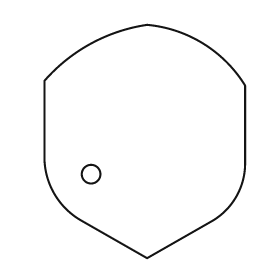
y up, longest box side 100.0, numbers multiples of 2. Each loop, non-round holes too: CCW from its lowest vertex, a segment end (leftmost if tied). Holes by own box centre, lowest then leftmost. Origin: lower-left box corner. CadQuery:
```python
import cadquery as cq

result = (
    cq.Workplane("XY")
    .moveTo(44.0, 0.0)
    .lineTo(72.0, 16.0)
    .threePointArc((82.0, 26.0), (86.0, 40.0))
    .lineTo(86.0, 74.0)
    .threePointArc((68.0, 92.0), (44.0, 100.0))
    .threePointArc((20.0, 92.0), (0.0, 76.0))
    .lineTo(0.0, 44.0)
    .threePointArc((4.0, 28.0), (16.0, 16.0))
    .close()
    .moveTo(20.0, 36.0)
    .circle(4.0)
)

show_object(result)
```